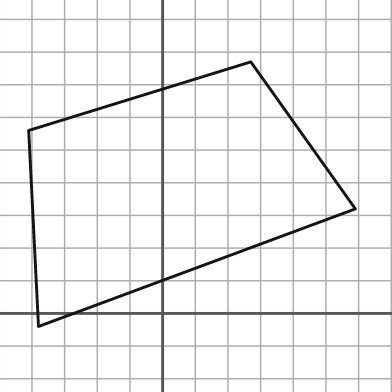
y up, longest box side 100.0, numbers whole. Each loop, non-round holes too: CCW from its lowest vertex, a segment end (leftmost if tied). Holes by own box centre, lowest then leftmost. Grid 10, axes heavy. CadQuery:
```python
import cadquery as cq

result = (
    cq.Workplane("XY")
    .moveTo(-38.0, -4.0)
    .lineTo(59.0, 32.0)
    .lineTo(27.0, 77.0)
    .lineTo(-41.0, 56.0)
    .close()
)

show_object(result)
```